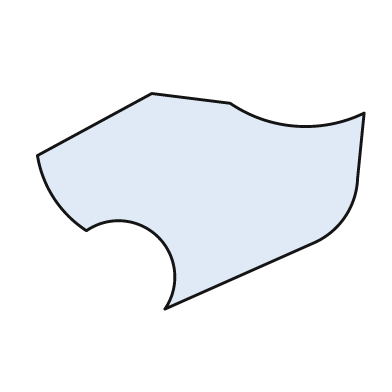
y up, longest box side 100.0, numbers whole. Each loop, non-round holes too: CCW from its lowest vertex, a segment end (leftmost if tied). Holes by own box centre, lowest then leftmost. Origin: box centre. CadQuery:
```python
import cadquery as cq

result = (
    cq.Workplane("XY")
    .moveTo(-11.0, -33.0)
    .lineTo(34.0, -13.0)
    .threePointArc((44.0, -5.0), (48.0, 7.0))
    .lineTo(50.0, 27.0)
    .threePointArc((29.0, 23.0), (9.0, 30.0))
    .lineTo(-15.0, 33.0)
    .lineTo(-50.0, 14.0)
    .threePointArc((-45.0, 1.0), (-35.0, -9.0))
    .threePointArc((-13.0, -11.0), (-11.0, -33.0))
    .close()
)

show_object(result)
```